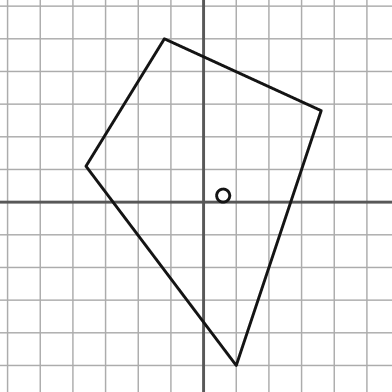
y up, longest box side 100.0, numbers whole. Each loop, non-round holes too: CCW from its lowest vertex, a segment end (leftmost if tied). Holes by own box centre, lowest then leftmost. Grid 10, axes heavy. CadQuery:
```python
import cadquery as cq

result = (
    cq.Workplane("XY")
    .moveTo(10.0, -50.0)
    .lineTo(36.0, 28.0)
    .lineTo(-12.0, 50.0)
    .lineTo(-36.0, 11.0)
    .close()
    .moveTo(6.0, 2.0)
    .circle(2.0)
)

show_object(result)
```